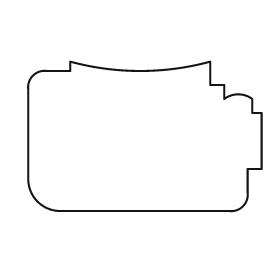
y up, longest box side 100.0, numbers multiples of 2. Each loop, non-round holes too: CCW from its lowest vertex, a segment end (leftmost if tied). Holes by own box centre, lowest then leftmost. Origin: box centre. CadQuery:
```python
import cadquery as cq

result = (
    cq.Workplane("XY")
    .moveTo(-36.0, -32.0)
    .lineTo(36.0, -32.0)
    .threePointArc((42.0, -30.0), (44.0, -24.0))
    .lineTo(44.0, -14.0)
    .lineTo(50.0, -14.0)
    .lineTo(50.0, 10.0)
    .lineTo(46.0, 10.0)
    .lineTo(46.0, 16.0)
    .threePointArc((40.0, 18.0), (34.0, 16.0))
    .lineTo(34.0, 22.0)
    .lineTo(28.0, 22.0)
    .lineTo(28.0, 32.0)
    .threePointArc((-2.0, 28.0), (-32.0, 32.0))
    .lineTo(-32.0, 28.0)
    .lineTo(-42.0, 28.0)
    .threePointArc((-48.0, 26.0), (-50.0, 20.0))
    .lineTo(-50.0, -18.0)
    .threePointArc((-46.0, -28.0), (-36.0, -32.0))
    .close()
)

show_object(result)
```